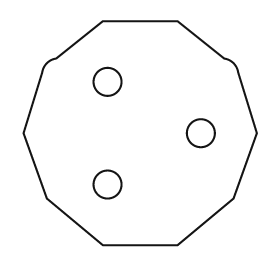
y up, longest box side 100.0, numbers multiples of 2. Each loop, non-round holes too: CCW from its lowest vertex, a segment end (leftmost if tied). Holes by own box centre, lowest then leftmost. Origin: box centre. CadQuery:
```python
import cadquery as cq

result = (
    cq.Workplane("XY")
    .moveTo(-16.0, -48.0)
    .lineTo(16.0, -48.0)
    .lineTo(40.0, -28.0)
    .lineTo(50.0, 0.0)
    .lineTo(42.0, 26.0)
    .threePointArc((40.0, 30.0), (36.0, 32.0))
    .lineTo(16.0, 48.0)
    .lineTo(-16.0, 48.0)
    .lineTo(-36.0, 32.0)
    .threePointArc((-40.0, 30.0), (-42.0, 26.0))
    .lineTo(-50.0, 0.0)
    .lineTo(-40.0, -28.0)
    .close()
    .moveTo(-14.0, -22.0)
    .circle(6.0)
    .moveTo(26.0, 0.0)
    .circle(6.0)
    .moveTo(-14.0, 22.0)
    .circle(6.0)
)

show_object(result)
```